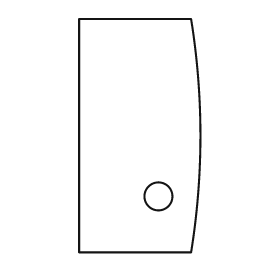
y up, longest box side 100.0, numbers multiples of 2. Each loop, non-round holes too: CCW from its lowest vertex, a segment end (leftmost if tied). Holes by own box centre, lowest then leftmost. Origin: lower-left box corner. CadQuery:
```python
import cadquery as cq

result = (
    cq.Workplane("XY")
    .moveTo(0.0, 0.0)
    .lineTo(48.0, 0.0)
    .threePointArc((52.0, 50.0), (48.0, 100.0))
    .lineTo(0.0, 100.0)
    .close()
    .moveTo(34.0, 24.0)
    .circle(6.0)
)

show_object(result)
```